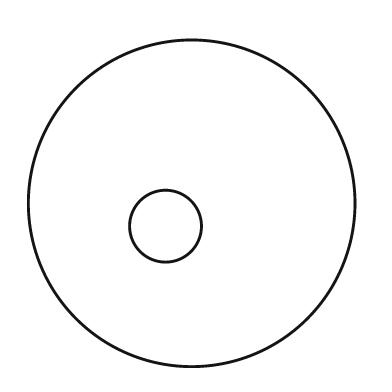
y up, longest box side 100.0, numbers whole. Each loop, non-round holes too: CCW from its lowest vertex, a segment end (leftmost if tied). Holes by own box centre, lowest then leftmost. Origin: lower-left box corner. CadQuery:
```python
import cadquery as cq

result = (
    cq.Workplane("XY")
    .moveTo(50.0, 50.0)
    .circle(50.0)
    .moveTo(42.0, 43.0)
    .circle(11.0)
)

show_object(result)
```